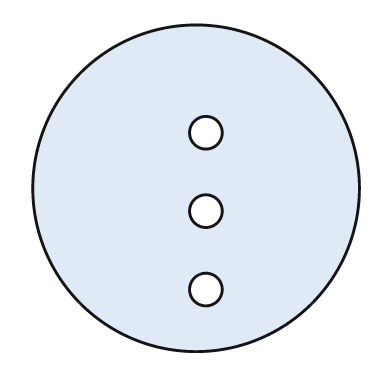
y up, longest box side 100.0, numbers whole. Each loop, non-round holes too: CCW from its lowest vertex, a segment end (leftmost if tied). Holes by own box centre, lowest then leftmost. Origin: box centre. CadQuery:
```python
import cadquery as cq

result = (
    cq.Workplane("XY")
    .moveTo(0.0, 0.0)
    .circle(50.0)
    .moveTo(3.0, -31.0)
    .circle(5.0)
    .moveTo(3.0, -7.0)
    .circle(5.0)
    .moveTo(3.0, 17.0)
    .circle(5.0)
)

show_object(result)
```